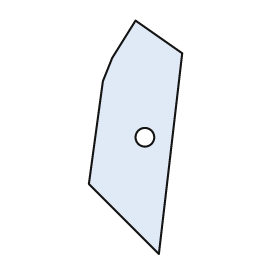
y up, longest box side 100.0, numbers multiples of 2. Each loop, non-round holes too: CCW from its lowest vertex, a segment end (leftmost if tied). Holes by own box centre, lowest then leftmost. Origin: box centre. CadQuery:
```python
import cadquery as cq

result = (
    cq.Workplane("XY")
    .moveTo(10.0, -50.0)
    .lineTo(20.0, 36.0)
    .lineTo(0.0, 50.0)
    .lineTo(-10.0, 34.0)
    .lineTo(-14.0, 24.0)
    .lineTo(-20.0, -20.0)
    .close()
    .moveTo(4.0, 0.0)
    .circle(4.0)
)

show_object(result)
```